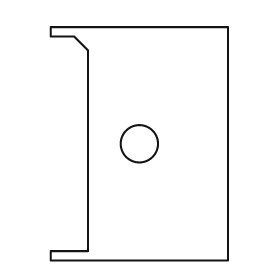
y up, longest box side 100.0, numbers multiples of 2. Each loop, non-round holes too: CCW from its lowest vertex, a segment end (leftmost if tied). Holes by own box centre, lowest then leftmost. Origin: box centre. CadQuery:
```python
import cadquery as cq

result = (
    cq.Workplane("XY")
    .moveTo(-38.0, -50.0)
    .lineTo(38.0, -50.0)
    .lineTo(38.0, 50.0)
    .lineTo(-38.0, 50.0)
    .lineTo(-38.0, 46.0)
    .lineTo(-28.0, 46.0)
    .lineTo(-22.0, 40.0)
    .lineTo(-22.0, -46.0)
    .lineTo(-38.0, -46.0)
    .close()
    .moveTo(0.0, 0.0)
    .circle(8.0)
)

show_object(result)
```